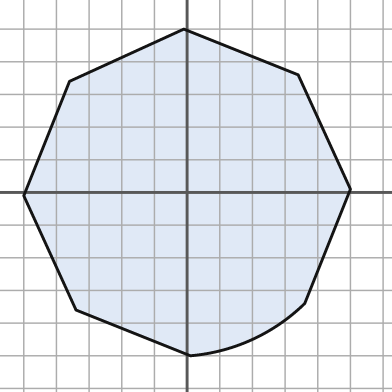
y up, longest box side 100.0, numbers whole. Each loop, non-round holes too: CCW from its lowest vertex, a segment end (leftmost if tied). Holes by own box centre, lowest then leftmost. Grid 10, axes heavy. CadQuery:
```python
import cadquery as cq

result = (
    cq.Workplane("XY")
    .moveTo(1.0, -50.0)
    .threePointArc((20.0, -45.0), (36.0, -34.0))
    .lineTo(50.0, 1.0)
    .lineTo(34.0, 36.0)
    .lineTo(-1.0, 50.0)
    .lineTo(-36.0, 34.0)
    .lineTo(-50.0, -1.0)
    .lineTo(-34.0, -36.0)
    .close()
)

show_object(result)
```